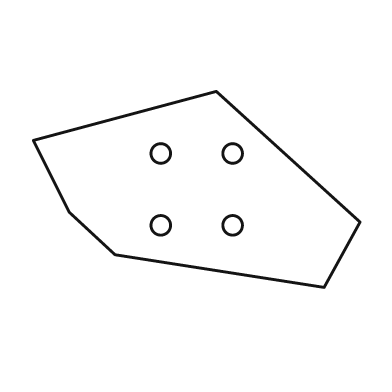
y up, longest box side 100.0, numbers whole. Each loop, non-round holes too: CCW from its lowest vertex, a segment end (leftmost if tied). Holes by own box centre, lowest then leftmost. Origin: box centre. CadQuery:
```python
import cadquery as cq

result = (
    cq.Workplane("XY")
    .moveTo(39.0, -30.0)
    .lineTo(50.0, -10.0)
    .lineTo(6.0, 30.0)
    .lineTo(-50.0, 15.0)
    .lineTo(-39.0, -7.0)
    .lineTo(-25.0, -20.0)
    .close()
    .moveTo(-11.0, -11.0)
    .circle(3.0)
    .moveTo(11.0, -11.0)
    .circle(3.0)
    .moveTo(-11.0, 11.0)
    .circle(3.0)
    .moveTo(11.0, 11.0)
    .circle(3.0)
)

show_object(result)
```